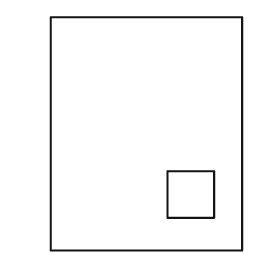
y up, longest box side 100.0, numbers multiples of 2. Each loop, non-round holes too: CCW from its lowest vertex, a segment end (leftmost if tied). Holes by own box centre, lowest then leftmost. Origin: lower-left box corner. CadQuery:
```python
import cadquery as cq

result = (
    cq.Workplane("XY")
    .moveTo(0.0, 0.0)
    .lineTo(82.0, 0.0)
    .lineTo(82.0, 100.0)
    .lineTo(0.0, 100.0)
    .close()
    .moveTo(50.0, 14.0)
    .lineTo(70.0, 14.0)
    .lineTo(70.0, 34.0)
    .lineTo(50.0, 34.0)
    .close()
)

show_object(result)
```